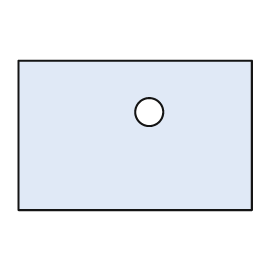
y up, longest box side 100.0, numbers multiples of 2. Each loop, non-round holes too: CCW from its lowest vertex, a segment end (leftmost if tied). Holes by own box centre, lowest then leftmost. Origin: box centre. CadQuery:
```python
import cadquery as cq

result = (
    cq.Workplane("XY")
    .moveTo(-50.0, -32.0)
    .lineTo(50.0, -32.0)
    .lineTo(50.0, 32.0)
    .lineTo(-50.0, 32.0)
    .close()
    .moveTo(6.0, 10.0)
    .circle(6.0)
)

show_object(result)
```